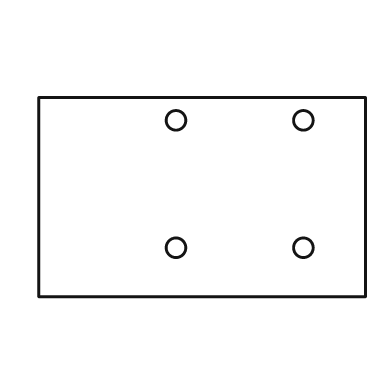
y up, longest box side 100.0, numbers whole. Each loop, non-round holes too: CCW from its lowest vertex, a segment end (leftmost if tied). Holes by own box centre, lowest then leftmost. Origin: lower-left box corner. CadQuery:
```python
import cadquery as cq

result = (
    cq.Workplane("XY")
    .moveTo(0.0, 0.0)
    .lineTo(100.0, 0.0)
    .lineTo(100.0, 61.0)
    .lineTo(0.0, 61.0)
    .close()
    .moveTo(42.0, 15.0)
    .circle(3.0)
    .moveTo(81.0, 15.0)
    .circle(3.0)
    .moveTo(42.0, 54.0)
    .circle(3.0)
    .moveTo(81.0, 54.0)
    .circle(3.0)
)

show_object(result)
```